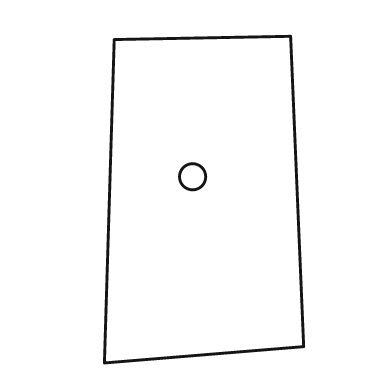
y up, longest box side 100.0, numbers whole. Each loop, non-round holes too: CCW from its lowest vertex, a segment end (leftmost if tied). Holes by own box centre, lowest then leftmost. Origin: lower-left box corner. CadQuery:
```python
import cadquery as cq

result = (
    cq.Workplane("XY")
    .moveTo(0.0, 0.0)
    .lineTo(61.0, 5.0)
    .lineTo(57.0, 100.0)
    .lineTo(3.0, 99.0)
    .close()
    .moveTo(27.0, 57.0)
    .circle(4.0)
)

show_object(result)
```